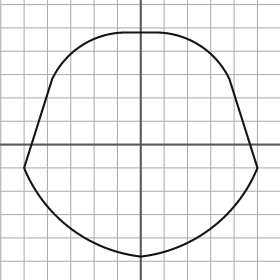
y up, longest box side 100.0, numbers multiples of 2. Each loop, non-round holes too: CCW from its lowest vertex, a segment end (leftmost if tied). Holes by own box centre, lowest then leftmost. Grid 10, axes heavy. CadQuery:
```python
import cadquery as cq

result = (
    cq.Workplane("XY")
    .moveTo(0.0, -48.0)
    .threePointArc((30.0, -36.0), (50.0, -10.0))
    .lineTo(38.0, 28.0)
    .threePointArc((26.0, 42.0), (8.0, 48.0))
    .lineTo(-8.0, 48.0)
    .threePointArc((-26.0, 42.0), (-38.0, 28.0))
    .lineTo(-50.0, -10.0)
    .threePointArc((-30.0, -36.0), (0.0, -48.0))
    .close()
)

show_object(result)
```